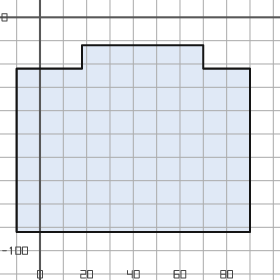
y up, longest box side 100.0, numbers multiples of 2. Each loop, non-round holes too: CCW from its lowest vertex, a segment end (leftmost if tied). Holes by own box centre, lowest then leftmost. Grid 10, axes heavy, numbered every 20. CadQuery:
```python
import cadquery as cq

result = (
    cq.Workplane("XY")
    .moveTo(-10.0, -92.0)
    .lineTo(90.0, -92.0)
    .lineTo(90.0, -22.0)
    .lineTo(70.0, -22.0)
    .lineTo(70.0, -12.0)
    .lineTo(18.0, -12.0)
    .lineTo(18.0, -22.0)
    .lineTo(-10.0, -22.0)
    .close()
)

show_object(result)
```